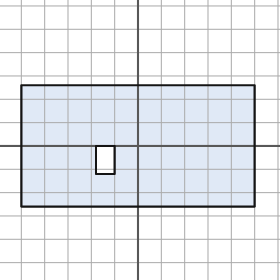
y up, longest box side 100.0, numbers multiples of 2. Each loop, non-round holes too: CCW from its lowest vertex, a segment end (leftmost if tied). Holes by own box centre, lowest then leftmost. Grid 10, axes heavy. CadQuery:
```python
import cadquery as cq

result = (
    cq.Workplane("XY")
    .moveTo(-50.0, -26.0)
    .lineTo(50.0, -26.0)
    .lineTo(50.0, 26.0)
    .lineTo(-50.0, 26.0)
    .close()
    .moveTo(-18.0, -12.0)
    .lineTo(-10.0, -12.0)
    .lineTo(-10.0, 0.0)
    .lineTo(-18.0, 0.0)
    .close()
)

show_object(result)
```